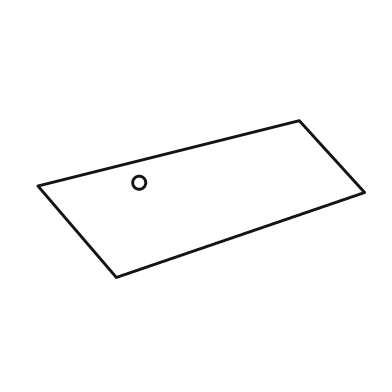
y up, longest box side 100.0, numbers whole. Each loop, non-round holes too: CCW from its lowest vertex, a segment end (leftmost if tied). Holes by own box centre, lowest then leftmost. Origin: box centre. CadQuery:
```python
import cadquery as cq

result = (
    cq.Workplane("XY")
    .moveTo(-26.0, -24.0)
    .lineTo(50.0, 2.0)
    .lineTo(30.0, 24.0)
    .lineTo(-50.0, 4.0)
    .close()
    .moveTo(-19.0, 5.0)
    .circle(2.0)
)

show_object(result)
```